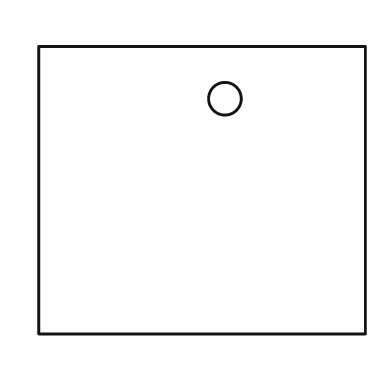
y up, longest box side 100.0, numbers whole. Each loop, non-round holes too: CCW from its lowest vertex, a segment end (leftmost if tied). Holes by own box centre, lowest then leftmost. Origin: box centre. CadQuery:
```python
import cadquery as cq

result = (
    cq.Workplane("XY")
    .moveTo(-50.0, -44.0)
    .lineTo(50.0, -44.0)
    .lineTo(50.0, 44.0)
    .lineTo(-50.0, 44.0)
    .close()
    .moveTo(7.0, 28.0)
    .circle(5.0)
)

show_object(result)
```